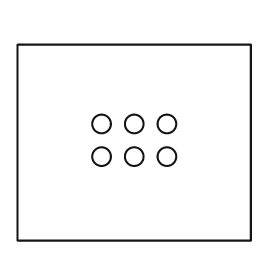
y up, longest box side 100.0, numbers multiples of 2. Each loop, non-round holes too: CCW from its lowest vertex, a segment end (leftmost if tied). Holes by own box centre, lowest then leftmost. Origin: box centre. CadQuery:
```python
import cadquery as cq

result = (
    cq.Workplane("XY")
    .moveTo(-50.0, -42.0)
    .lineTo(50.0, -42.0)
    .lineTo(50.0, 42.0)
    .lineTo(-50.0, 42.0)
    .close()
    .moveTo(-14.0, -6.0)
    .circle(4.0)
    .moveTo(0.0, -6.0)
    .circle(4.0)
    .moveTo(14.0, -6.0)
    .circle(4.0)
    .moveTo(-14.0, 8.0)
    .circle(4.0)
    .moveTo(0.0, 8.0)
    .circle(4.0)
    .moveTo(14.0, 8.0)
    .circle(4.0)
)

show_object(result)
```